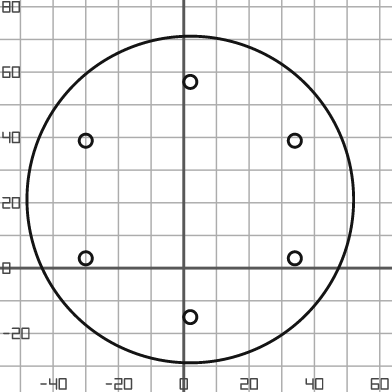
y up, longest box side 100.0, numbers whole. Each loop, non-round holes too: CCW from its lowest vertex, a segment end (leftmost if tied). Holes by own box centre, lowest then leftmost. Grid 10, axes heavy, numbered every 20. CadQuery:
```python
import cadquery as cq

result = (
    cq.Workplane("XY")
    .moveTo(2.0, 21.0)
    .circle(50.0)
    .moveTo(2.0, -15.0)
    .circle(2.0)
    .moveTo(-30.0, 3.0)
    .circle(2.0)
    .moveTo(34.0, 3.0)
    .circle(2.0)
    .moveTo(-30.0, 39.0)
    .circle(2.0)
    .moveTo(34.0, 39.0)
    .circle(2.0)
    .moveTo(2.0, 57.0)
    .circle(2.0)
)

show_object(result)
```